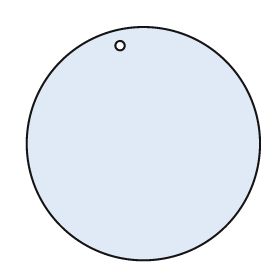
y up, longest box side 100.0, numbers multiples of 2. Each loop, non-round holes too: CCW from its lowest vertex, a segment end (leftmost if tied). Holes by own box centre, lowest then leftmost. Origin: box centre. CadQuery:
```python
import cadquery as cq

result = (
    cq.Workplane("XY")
    .moveTo(0.0, 0.0)
    .circle(50.0)
    .moveTo(-10.0, 42.0)
    .circle(2.0)
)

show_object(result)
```